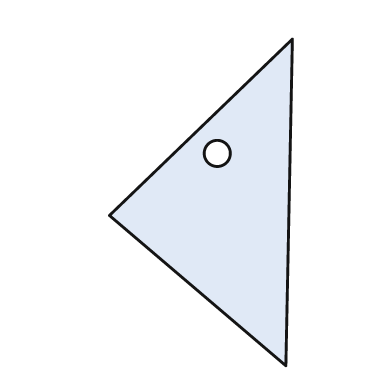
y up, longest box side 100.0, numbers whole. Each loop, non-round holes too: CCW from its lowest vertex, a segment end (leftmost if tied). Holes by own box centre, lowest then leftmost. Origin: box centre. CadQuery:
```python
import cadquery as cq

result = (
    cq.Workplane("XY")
    .moveTo(26.0, -50.0)
    .lineTo(28.0, 50.0)
    .lineTo(-28.0, -4.0)
    .close()
    .moveTo(5.0, 15.0)
    .circle(4.0)
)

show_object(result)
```